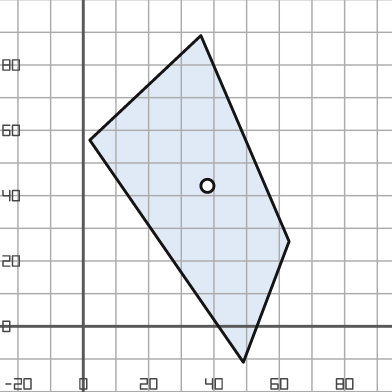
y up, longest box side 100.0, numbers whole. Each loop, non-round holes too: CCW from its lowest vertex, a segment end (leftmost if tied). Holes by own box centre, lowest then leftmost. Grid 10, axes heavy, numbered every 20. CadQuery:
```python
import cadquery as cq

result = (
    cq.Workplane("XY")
    .moveTo(49.0, -11.0)
    .lineTo(63.0, 26.0)
    .lineTo(36.0, 89.0)
    .lineTo(2.0, 57.0)
    .close()
    .moveTo(38.0, 43.0)
    .circle(2.0)
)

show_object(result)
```